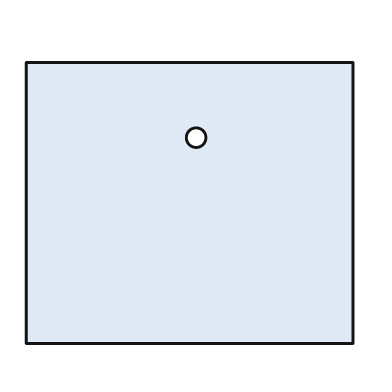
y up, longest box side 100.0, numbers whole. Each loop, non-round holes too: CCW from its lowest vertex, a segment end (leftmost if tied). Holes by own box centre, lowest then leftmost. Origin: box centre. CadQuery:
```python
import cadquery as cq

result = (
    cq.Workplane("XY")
    .moveTo(-50.0, -43.0)
    .lineTo(50.0, -43.0)
    .lineTo(50.0, 43.0)
    .lineTo(-50.0, 43.0)
    .close()
    .moveTo(2.0, 20.0)
    .circle(3.0)
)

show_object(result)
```